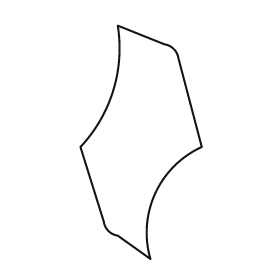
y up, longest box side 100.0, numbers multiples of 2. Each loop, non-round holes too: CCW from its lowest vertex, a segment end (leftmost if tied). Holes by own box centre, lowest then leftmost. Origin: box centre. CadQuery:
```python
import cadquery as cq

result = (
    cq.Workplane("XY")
    .moveTo(4.0, -50.0)
    .threePointArc((6.0, -22.0), (26.0, -2.0))
    .lineTo(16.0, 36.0)
    .threePointArc((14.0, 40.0), (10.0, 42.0))
    .lineTo(-10.0, 50.0)
    .threePointArc((-12.0, 22.0), (-26.0, -2.0))
    .lineTo(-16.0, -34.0)
    .threePointArc((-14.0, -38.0), (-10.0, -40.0))
    .close()
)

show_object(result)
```